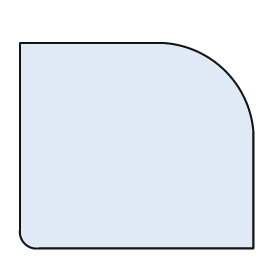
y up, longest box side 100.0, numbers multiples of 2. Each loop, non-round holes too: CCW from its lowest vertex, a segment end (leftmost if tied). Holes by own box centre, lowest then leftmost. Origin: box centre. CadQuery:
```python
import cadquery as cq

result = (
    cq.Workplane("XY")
    .moveTo(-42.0, -44.0)
    .lineTo(50.0, -44.0)
    .lineTo(50.0, 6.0)
    .threePointArc((38.0, 32.0), (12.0, 44.0))
    .lineTo(-50.0, 44.0)
    .lineTo(-50.0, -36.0)
    .threePointArc((-48.0, -42.0), (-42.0, -44.0))
    .close()
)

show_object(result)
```